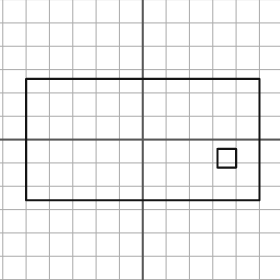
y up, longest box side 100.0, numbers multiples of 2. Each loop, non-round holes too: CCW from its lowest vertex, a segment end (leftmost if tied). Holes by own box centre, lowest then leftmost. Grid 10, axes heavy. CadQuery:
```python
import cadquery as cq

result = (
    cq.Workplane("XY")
    .moveTo(-50.0, -26.0)
    .lineTo(50.0, -26.0)
    .lineTo(50.0, 26.0)
    .lineTo(-50.0, 26.0)
    .close()
    .moveTo(32.0, -12.0)
    .lineTo(40.0, -12.0)
    .lineTo(40.0, -4.0)
    .lineTo(32.0, -4.0)
    .close()
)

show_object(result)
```